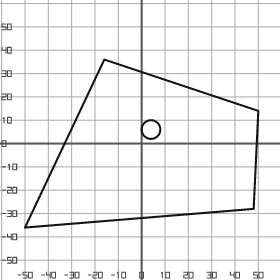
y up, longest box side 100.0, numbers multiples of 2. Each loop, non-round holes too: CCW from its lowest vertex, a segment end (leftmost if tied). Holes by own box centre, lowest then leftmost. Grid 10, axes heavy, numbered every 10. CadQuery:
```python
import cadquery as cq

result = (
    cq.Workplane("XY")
    .moveTo(-50.0, -36.0)
    .lineTo(48.0, -28.0)
    .lineTo(50.0, 14.0)
    .lineTo(-16.0, 36.0)
    .close()
    .moveTo(4.0, 6.0)
    .circle(4.0)
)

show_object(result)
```